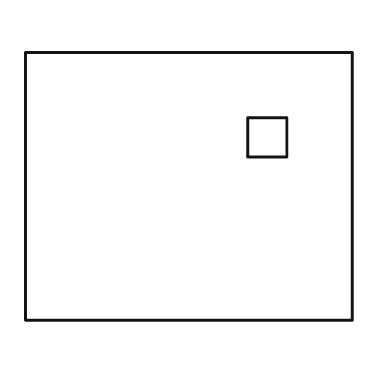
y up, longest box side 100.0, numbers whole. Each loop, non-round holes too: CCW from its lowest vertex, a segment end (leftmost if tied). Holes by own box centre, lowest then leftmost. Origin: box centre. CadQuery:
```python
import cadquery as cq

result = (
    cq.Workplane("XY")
    .moveTo(-50.0, -41.0)
    .lineTo(50.0, -41.0)
    .lineTo(50.0, 41.0)
    .lineTo(-50.0, 41.0)
    .close()
    .moveTo(18.0, 9.0)
    .lineTo(30.0, 9.0)
    .lineTo(30.0, 21.0)
    .lineTo(18.0, 21.0)
    .close()
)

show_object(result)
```